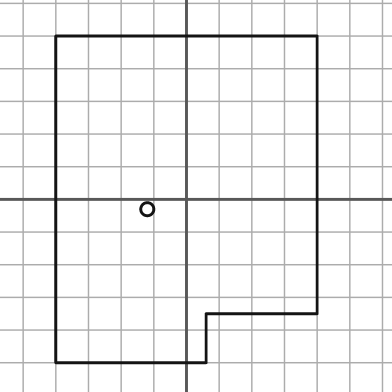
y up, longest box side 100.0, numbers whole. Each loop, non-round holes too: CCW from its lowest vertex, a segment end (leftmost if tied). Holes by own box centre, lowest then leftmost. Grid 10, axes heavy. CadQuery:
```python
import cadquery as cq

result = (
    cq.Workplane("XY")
    .moveTo(-40.0, -50.0)
    .lineTo(6.0, -50.0)
    .lineTo(6.0, -35.0)
    .lineTo(40.0, -35.0)
    .lineTo(40.0, 50.0)
    .lineTo(-40.0, 50.0)
    .close()
    .moveTo(-12.0, -3.0)
    .circle(2.0)
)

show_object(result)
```